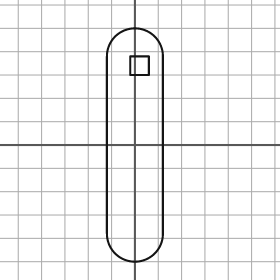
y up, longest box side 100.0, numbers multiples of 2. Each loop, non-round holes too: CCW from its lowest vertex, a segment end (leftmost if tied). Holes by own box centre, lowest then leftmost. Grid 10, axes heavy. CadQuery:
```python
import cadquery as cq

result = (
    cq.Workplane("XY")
    .moveTo(-12.0, -38.0)
    .threePointArc((0.0, -50.0), (12.0, -38.0))
    .lineTo(12.0, 38.0)
    .threePointArc((0.0, 50.0), (-12.0, 38.0))
    .close()
    .moveTo(-2.0, 30.0)
    .lineTo(6.0, 30.0)
    .lineTo(6.0, 38.0)
    .lineTo(-2.0, 38.0)
    .close()
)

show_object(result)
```